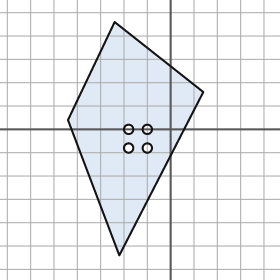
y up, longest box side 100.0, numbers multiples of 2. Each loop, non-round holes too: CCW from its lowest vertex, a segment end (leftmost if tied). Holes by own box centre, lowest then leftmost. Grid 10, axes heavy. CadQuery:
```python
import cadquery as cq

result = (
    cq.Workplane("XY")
    .moveTo(-22.0, -54.0)
    .lineTo(14.0, 16.0)
    .lineTo(-24.0, 46.0)
    .lineTo(-44.0, 4.0)
    .close()
    .moveTo(-18.0, -8.0)
    .circle(2.0)
    .moveTo(-10.0, -8.0)
    .circle(2.0)
    .moveTo(-18.0, 0.0)
    .circle(2.0)
    .moveTo(-10.0, 0.0)
    .circle(2.0)
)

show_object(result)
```